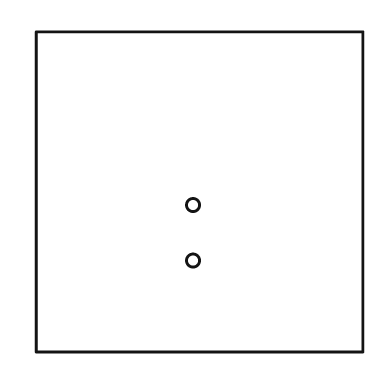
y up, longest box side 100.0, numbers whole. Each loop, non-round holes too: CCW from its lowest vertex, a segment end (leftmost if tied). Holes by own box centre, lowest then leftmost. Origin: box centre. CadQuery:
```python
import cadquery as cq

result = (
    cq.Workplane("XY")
    .moveTo(-50.0, -49.0)
    .lineTo(50.0, -49.0)
    .lineTo(50.0, 49.0)
    .lineTo(-50.0, 49.0)
    .close()
    .moveTo(-2.0, -21.0)
    .circle(2.0)
    .moveTo(-2.0, -4.0)
    .circle(2.0)
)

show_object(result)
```